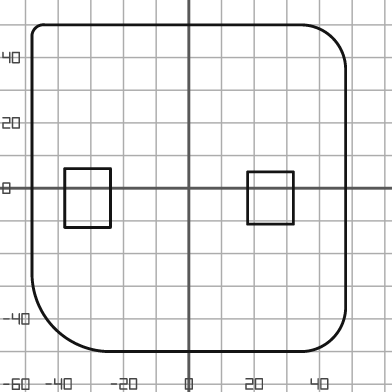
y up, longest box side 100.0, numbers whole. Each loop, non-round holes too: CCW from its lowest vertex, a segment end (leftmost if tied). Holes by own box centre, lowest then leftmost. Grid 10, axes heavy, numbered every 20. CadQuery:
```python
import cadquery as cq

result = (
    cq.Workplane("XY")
    .moveTo(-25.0, -50.0)
    .lineTo(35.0, -50.0)
    .threePointArc((44.0, -46.0), (48.0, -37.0))
    .lineTo(48.0, 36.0)
    .threePointArc((44.0, 46.0), (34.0, 50.0))
    .lineTo(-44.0, 50.0)
    .threePointArc((-47.0, 49.0), (-48.0, 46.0))
    .lineTo(-48.0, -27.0)
    .threePointArc((-41.0, -43.0), (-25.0, -50.0))
    .close()
    .moveTo(-38.0, -12.0)
    .lineTo(-24.0, -12.0)
    .lineTo(-24.0, 6.0)
    .lineTo(-38.0, 6.0)
    .close()
    .moveTo(18.0, -11.0)
    .lineTo(32.0, -11.0)
    .lineTo(32.0, 5.0)
    .lineTo(18.0, 5.0)
    .close()
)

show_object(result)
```